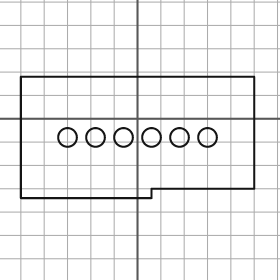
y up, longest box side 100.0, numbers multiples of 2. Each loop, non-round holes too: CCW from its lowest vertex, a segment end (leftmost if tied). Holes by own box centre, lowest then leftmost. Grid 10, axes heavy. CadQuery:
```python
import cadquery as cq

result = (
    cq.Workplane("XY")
    .moveTo(-50.0, -34.0)
    .lineTo(6.0, -34.0)
    .lineTo(6.0, -30.0)
    .lineTo(50.0, -30.0)
    .lineTo(50.0, 18.0)
    .lineTo(-50.0, 18.0)
    .close()
    .moveTo(-30.0, -8.0)
    .circle(4.0)
    .moveTo(-18.0, -8.0)
    .circle(4.0)
    .moveTo(-6.0, -8.0)
    .circle(4.0)
    .moveTo(6.0, -8.0)
    .circle(4.0)
    .moveTo(18.0, -8.0)
    .circle(4.0)
    .moveTo(30.0, -8.0)
    .circle(4.0)
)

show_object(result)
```